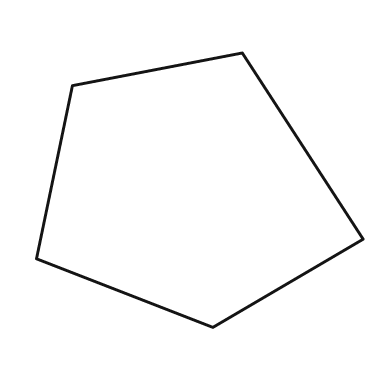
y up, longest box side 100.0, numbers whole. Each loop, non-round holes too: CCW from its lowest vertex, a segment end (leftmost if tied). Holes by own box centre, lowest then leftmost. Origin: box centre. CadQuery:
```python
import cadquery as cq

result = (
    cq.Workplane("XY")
    .moveTo(4.0, -42.0)
    .lineTo(50.0, -15.0)
    .lineTo(13.0, 42.0)
    .lineTo(-39.0, 32.0)
    .lineTo(-50.0, -21.0)
    .close()
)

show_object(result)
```